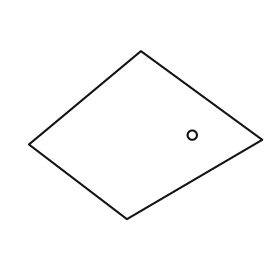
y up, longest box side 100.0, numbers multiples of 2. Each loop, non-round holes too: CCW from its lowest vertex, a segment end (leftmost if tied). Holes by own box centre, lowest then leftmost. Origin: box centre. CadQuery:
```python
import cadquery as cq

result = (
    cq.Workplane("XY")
    .moveTo(-8.0, -36.0)
    .lineTo(50.0, -2.0)
    .lineTo(-2.0, 36.0)
    .lineTo(-50.0, -4.0)
    .close()
    .moveTo(20.0, 0.0)
    .circle(2.0)
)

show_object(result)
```